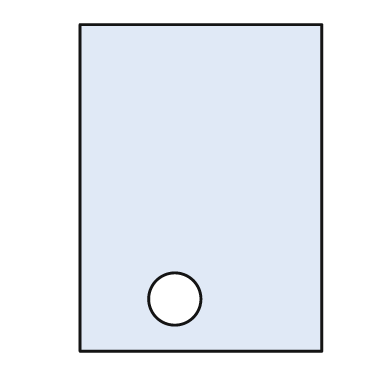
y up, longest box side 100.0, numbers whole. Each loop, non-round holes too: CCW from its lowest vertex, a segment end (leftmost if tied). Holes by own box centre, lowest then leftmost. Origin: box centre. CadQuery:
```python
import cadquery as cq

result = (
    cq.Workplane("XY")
    .moveTo(-37.0, -50.0)
    .lineTo(37.0, -50.0)
    .lineTo(37.0, 50.0)
    .lineTo(-37.0, 50.0)
    .close()
    .moveTo(-8.0, -34.0)
    .circle(8.0)
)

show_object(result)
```